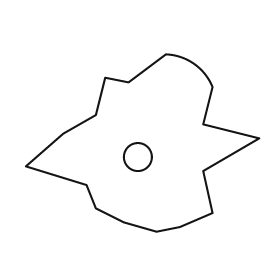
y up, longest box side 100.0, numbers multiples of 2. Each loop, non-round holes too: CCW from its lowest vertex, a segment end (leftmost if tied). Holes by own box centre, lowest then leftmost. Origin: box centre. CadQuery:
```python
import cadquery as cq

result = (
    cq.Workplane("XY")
    .moveTo(6.0, -38.0)
    .lineTo(16.0, -36.0)
    .lineTo(30.0, -30.0)
    .lineTo(26.0, -12.0)
    .lineTo(50.0, 2.0)
    .lineTo(26.0, 8.0)
    .lineTo(30.0, 24.0)
    .threePointArc((22.0, 34.0), (10.0, 38.0))
    .lineTo(-6.0, 26.0)
    .lineTo(-16.0, 28.0)
    .lineTo(-20.0, 12.0)
    .lineTo(-34.0, 4.0)
    .lineTo(-50.0, -10.0)
    .lineTo(-24.0, -18.0)
    .lineTo(-20.0, -28.0)
    .lineTo(-8.0, -34.0)
    .close()
    .moveTo(-2.0, -6.0)
    .circle(6.0)
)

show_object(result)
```